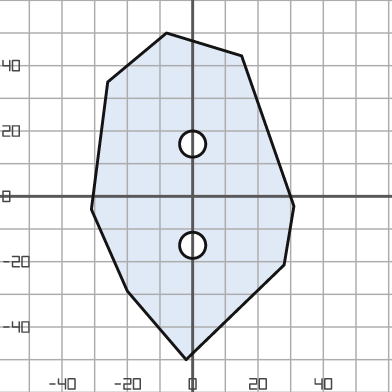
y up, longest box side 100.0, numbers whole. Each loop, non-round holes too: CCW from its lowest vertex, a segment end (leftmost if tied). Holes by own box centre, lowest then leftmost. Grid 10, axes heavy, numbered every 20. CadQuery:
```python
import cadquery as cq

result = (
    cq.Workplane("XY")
    .moveTo(-2.0, -50.0)
    .lineTo(28.0, -21.0)
    .lineTo(31.0, -3.0)
    .lineTo(15.0, 43.0)
    .lineTo(-8.0, 50.0)
    .lineTo(-26.0, 35.0)
    .lineTo(-31.0, -4.0)
    .lineTo(-20.0, -29.0)
    .close()
    .moveTo(0.0, -15.0)
    .circle(4.0)
    .moveTo(0.0, 16.0)
    .circle(4.0)
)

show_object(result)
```